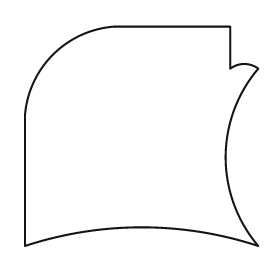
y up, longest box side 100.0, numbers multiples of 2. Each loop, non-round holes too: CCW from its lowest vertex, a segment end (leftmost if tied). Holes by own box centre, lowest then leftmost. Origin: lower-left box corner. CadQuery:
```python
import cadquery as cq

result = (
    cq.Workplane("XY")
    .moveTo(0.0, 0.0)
    .threePointArc((50.0, 8.0), (100.0, 0.0))
    .threePointArc((86.0, 38.0), (100.0, 76.0))
    .threePointArc((94.0, 78.0), (88.0, 76.0))
    .lineTo(88.0, 94.0)
    .lineTo(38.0, 94.0)
    .threePointArc((12.0, 82.0), (0.0, 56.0))
    .close()
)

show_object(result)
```